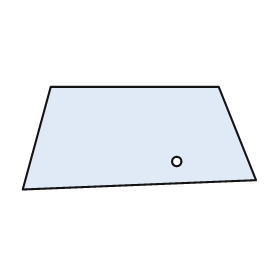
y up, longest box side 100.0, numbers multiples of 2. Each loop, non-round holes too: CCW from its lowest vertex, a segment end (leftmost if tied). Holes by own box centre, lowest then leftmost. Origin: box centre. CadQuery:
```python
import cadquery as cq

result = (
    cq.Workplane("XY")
    .moveTo(-50.0, -22.0)
    .lineTo(50.0, -18.0)
    .lineTo(34.0, 22.0)
    .lineTo(-38.0, 22.0)
    .close()
    .moveTo(16.0, -10.0)
    .circle(2.0)
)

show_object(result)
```